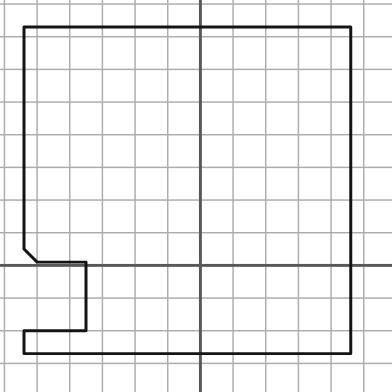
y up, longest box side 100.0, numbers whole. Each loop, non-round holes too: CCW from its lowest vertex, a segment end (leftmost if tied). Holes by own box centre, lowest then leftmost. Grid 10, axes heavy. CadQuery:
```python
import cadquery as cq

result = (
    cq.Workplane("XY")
    .moveTo(-54.0, -27.0)
    .lineTo(46.0, -27.0)
    .lineTo(46.0, 73.0)
    .lineTo(-54.0, 73.0)
    .lineTo(-54.0, 5.0)
    .lineTo(-50.0, 1.0)
    .lineTo(-35.0, 1.0)
    .lineTo(-35.0, -20.0)
    .lineTo(-54.0, -20.0)
    .close()
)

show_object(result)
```